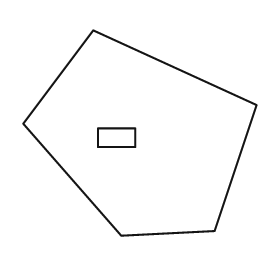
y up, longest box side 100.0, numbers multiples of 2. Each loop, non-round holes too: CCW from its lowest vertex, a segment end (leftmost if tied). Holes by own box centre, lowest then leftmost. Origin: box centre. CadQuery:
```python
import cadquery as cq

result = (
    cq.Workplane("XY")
    .moveTo(-8.0, -44.0)
    .lineTo(32.0, -42.0)
    .lineTo(50.0, 12.0)
    .lineTo(-20.0, 44.0)
    .lineTo(-50.0, 4.0)
    .close()
    .moveTo(-18.0, -6.0)
    .lineTo(-2.0, -6.0)
    .lineTo(-2.0, 2.0)
    .lineTo(-18.0, 2.0)
    .close()
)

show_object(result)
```